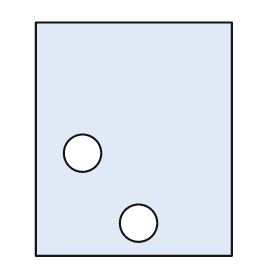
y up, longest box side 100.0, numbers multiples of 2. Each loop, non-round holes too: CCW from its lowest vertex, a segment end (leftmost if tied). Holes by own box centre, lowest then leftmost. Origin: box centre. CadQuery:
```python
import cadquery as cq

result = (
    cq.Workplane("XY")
    .moveTo(-42.0, -50.0)
    .lineTo(42.0, -50.0)
    .lineTo(42.0, 50.0)
    .lineTo(-42.0, 50.0)
    .close()
    .moveTo(2.0, -36.0)
    .circle(8.0)
    .moveTo(-22.0, -6.0)
    .circle(8.0)
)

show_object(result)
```